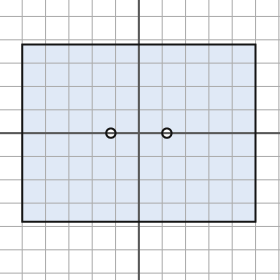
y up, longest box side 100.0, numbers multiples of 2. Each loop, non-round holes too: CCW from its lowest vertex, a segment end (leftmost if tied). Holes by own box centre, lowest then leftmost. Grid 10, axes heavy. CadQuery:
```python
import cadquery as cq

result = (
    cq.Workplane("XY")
    .moveTo(-50.0, -38.0)
    .lineTo(50.0, -38.0)
    .lineTo(50.0, 38.0)
    .lineTo(-50.0, 38.0)
    .close()
    .moveTo(-12.0, 0.0)
    .circle(2.0)
    .moveTo(12.0, 0.0)
    .circle(2.0)
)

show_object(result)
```